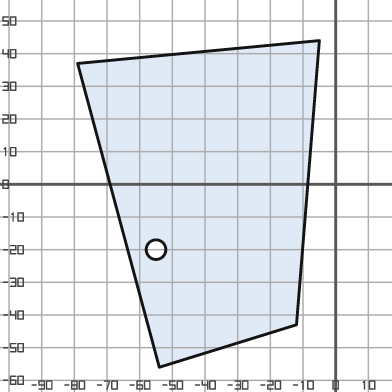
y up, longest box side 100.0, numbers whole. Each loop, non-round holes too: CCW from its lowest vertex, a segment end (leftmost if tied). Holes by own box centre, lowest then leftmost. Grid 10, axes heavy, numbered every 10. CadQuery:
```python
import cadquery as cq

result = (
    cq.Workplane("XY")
    .moveTo(-54.0, -56.0)
    .lineTo(-12.0, -43.0)
    .lineTo(-5.0, 44.0)
    .lineTo(-79.0, 37.0)
    .close()
    .moveTo(-55.0, -20.0)
    .circle(3.0)
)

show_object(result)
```